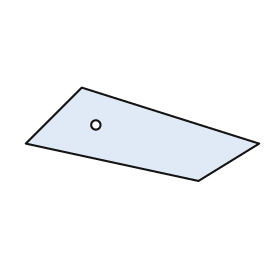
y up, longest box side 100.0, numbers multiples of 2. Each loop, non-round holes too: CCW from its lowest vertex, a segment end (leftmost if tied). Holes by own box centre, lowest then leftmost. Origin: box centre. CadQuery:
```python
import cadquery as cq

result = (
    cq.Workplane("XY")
    .moveTo(24.0, -20.0)
    .lineTo(50.0, -4.0)
    .lineTo(-26.0, 20.0)
    .lineTo(-50.0, -4.0)
    .close()
    .moveTo(-20.0, 4.0)
    .circle(2.0)
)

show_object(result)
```